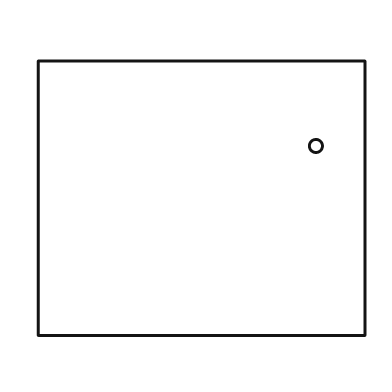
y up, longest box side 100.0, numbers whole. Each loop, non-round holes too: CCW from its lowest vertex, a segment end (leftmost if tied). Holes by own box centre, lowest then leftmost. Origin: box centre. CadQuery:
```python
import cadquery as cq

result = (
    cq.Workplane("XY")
    .moveTo(-50.0, -42.0)
    .lineTo(50.0, -42.0)
    .lineTo(50.0, 42.0)
    .lineTo(-50.0, 42.0)
    .close()
    .moveTo(35.0, 16.0)
    .circle(2.0)
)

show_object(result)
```